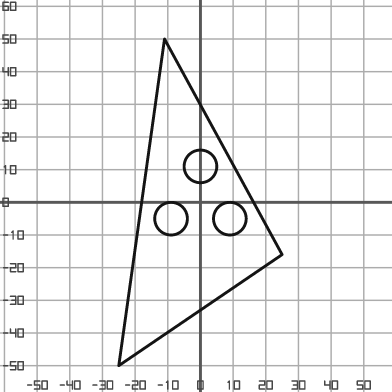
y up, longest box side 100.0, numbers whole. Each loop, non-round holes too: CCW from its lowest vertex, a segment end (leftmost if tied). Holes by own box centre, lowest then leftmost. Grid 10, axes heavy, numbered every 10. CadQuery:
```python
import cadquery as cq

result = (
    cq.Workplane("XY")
    .moveTo(-25.0, -50.0)
    .lineTo(25.0, -16.0)
    .lineTo(-11.0, 50.0)
    .close()
    .moveTo(-9.0, -5.0)
    .circle(5.0)
    .moveTo(9.0, -5.0)
    .circle(5.0)
    .moveTo(0.0, 11.0)
    .circle(5.0)
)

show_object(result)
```